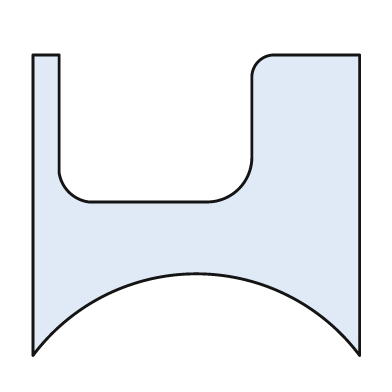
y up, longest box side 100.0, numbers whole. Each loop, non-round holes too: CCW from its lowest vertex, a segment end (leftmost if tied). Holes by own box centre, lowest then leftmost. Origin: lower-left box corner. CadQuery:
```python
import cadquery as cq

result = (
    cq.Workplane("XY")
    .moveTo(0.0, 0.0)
    .threePointArc((50.0, 25.0), (100.0, 0.0))
    .lineTo(100.0, 92.0)
    .lineTo(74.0, 92.0)
    .threePointArc((69.0, 90.0), (67.0, 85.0))
    .lineTo(67.0, 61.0)
    .threePointArc((63.0, 51.0), (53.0, 47.0))
    .lineTo(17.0, 47.0)
    .threePointArc((11.0, 50.0), (8.0, 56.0))
    .lineTo(8.0, 92.0)
    .lineTo(0.0, 92.0)
    .close()
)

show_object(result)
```